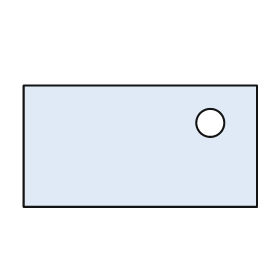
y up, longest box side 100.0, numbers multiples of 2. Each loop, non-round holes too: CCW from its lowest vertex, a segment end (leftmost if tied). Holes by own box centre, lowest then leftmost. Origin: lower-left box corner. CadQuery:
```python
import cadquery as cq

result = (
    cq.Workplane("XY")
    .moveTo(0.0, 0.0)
    .lineTo(100.0, 0.0)
    .lineTo(100.0, 52.0)
    .lineTo(0.0, 52.0)
    .close()
    .moveTo(80.0, 36.0)
    .circle(6.0)
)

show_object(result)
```